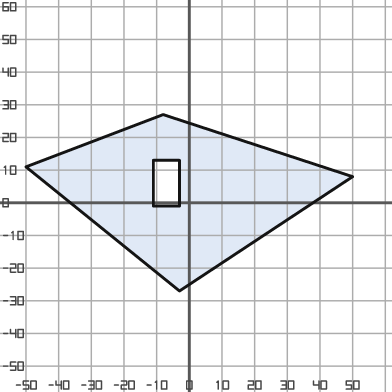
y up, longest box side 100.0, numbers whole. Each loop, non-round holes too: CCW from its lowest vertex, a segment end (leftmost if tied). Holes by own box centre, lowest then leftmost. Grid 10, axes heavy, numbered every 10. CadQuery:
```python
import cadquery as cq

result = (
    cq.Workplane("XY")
    .moveTo(-3.0, -27.0)
    .lineTo(50.0, 8.0)
    .lineTo(-8.0, 27.0)
    .lineTo(-50.0, 11.0)
    .close()
    .moveTo(-11.0, -1.0)
    .lineTo(-3.0, -1.0)
    .lineTo(-3.0, 13.0)
    .lineTo(-11.0, 13.0)
    .close()
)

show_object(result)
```